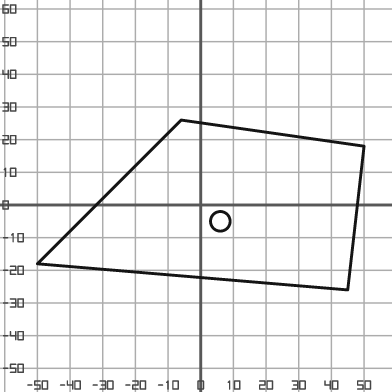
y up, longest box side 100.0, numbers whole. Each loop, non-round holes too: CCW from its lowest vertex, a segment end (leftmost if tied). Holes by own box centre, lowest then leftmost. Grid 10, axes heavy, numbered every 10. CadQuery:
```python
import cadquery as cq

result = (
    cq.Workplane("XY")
    .moveTo(45.0, -26.0)
    .lineTo(50.0, 18.0)
    .lineTo(-6.0, 26.0)
    .lineTo(-50.0, -18.0)
    .close()
    .moveTo(6.0, -5.0)
    .circle(3.0)
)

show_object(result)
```